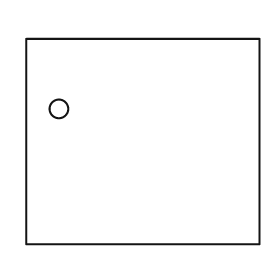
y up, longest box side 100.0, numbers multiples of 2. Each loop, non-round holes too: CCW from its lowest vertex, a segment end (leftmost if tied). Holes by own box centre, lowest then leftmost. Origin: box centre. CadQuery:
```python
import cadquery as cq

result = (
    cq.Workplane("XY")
    .moveTo(-50.0, -44.0)
    .lineTo(50.0, -44.0)
    .lineTo(50.0, 44.0)
    .lineTo(-50.0, 44.0)
    .close()
    .moveTo(-36.0, 14.0)
    .circle(4.0)
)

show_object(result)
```